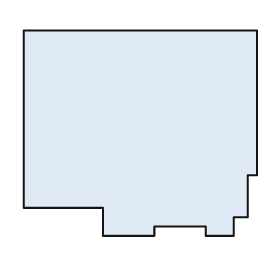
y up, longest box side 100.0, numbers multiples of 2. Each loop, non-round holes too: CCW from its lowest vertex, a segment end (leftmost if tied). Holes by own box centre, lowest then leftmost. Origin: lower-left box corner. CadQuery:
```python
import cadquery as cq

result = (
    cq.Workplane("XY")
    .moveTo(34.0, 0.0)
    .lineTo(56.0, 0.0)
    .lineTo(56.0, 4.0)
    .lineTo(78.0, 4.0)
    .lineTo(78.0, 0.0)
    .lineTo(90.0, 0.0)
    .lineTo(90.0, 8.0)
    .lineTo(96.0, 8.0)
    .lineTo(96.0, 26.0)
    .lineTo(100.0, 26.0)
    .lineTo(100.0, 88.0)
    .lineTo(0.0, 88.0)
    .lineTo(0.0, 12.0)
    .lineTo(34.0, 12.0)
    .close()
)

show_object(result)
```